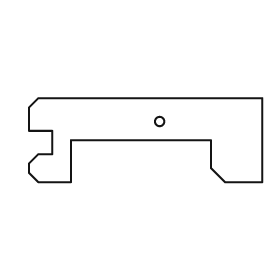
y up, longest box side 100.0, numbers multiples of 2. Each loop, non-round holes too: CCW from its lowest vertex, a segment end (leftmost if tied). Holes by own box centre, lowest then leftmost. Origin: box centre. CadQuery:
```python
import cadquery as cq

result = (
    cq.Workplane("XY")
    .moveTo(-46.0, -18.0)
    .lineTo(-32.0, -18.0)
    .lineTo(-32.0, 0.0)
    .lineTo(28.0, 0.0)
    .lineTo(28.0, -12.0)
    .lineTo(34.0, -18.0)
    .lineTo(50.0, -18.0)
    .lineTo(50.0, 18.0)
    .lineTo(-46.0, 18.0)
    .lineTo(-50.0, 14.0)
    .lineTo(-50.0, 4.0)
    .lineTo(-40.0, 4.0)
    .lineTo(-40.0, -6.0)
    .lineTo(-46.0, -6.0)
    .lineTo(-50.0, -10.0)
    .lineTo(-50.0, -14.0)
    .close()
    .moveTo(6.0, 8.0)
    .circle(2.0)
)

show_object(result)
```